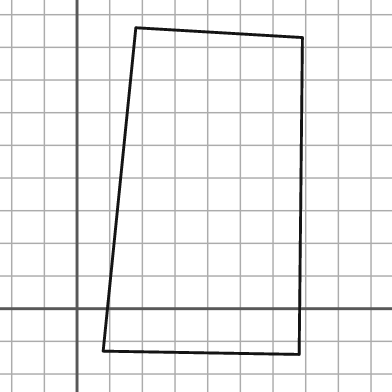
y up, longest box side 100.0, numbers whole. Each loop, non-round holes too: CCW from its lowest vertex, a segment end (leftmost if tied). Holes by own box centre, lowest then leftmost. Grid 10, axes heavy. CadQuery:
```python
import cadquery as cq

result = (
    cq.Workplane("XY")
    .moveTo(68.0, -14.0)
    .lineTo(69.0, 83.0)
    .lineTo(18.0, 86.0)
    .lineTo(8.0, -13.0)
    .close()
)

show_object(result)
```